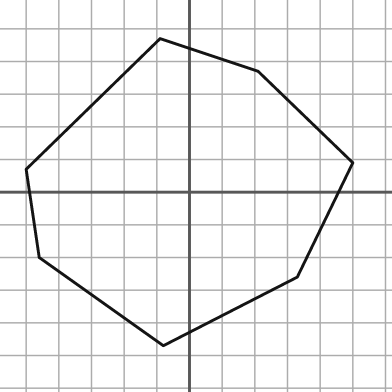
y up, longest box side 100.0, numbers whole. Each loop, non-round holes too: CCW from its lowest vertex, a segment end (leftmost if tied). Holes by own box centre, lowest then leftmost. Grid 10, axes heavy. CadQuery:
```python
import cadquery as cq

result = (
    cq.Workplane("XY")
    .moveTo(-8.0, -47.0)
    .lineTo(33.0, -26.0)
    .lineTo(50.0, 9.0)
    .lineTo(21.0, 37.0)
    .lineTo(-9.0, 47.0)
    .lineTo(-50.0, 7.0)
    .lineTo(-46.0, -20.0)
    .close()
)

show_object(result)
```